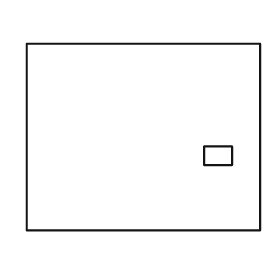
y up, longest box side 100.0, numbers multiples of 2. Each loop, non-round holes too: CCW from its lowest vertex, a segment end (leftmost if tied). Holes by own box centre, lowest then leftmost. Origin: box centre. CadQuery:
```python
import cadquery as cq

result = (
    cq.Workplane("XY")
    .moveTo(-50.0, -40.0)
    .lineTo(50.0, -40.0)
    .lineTo(50.0, 40.0)
    .lineTo(-50.0, 40.0)
    .close()
    .moveTo(26.0, -12.0)
    .lineTo(38.0, -12.0)
    .lineTo(38.0, -4.0)
    .lineTo(26.0, -4.0)
    .close()
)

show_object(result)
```